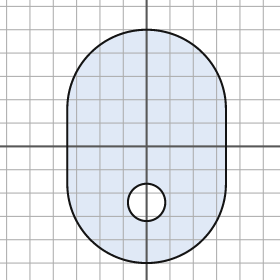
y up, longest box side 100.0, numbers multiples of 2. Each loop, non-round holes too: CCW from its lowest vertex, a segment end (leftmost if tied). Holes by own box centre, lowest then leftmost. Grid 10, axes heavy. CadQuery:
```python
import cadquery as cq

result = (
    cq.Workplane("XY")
    .moveTo(-34.0, -16.0)
    .threePointArc((0.0, -50.0), (34.0, -16.0))
    .lineTo(34.0, 16.0)
    .threePointArc((0.0, 50.0), (-34.0, 16.0))
    .close()
    .moveTo(0.0, -24.0)
    .circle(8.0)
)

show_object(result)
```